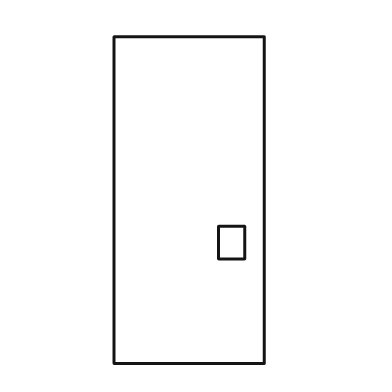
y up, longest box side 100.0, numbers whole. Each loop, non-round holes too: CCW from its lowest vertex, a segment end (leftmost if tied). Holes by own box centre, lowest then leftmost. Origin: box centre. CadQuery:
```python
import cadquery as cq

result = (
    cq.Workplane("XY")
    .moveTo(-23.0, -50.0)
    .lineTo(23.0, -50.0)
    .lineTo(23.0, 50.0)
    .lineTo(-23.0, 50.0)
    .close()
    .moveTo(9.0, -18.0)
    .lineTo(17.0, -18.0)
    .lineTo(17.0, -8.0)
    .lineTo(9.0, -8.0)
    .close()
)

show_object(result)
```